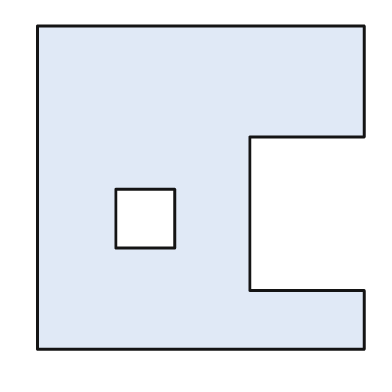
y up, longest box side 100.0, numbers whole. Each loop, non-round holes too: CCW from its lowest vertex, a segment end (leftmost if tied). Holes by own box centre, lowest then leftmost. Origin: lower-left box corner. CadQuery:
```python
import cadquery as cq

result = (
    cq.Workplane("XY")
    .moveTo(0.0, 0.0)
    .lineTo(100.0, 0.0)
    .lineTo(100.0, 18.0)
    .lineTo(65.0, 18.0)
    .lineTo(65.0, 65.0)
    .lineTo(100.0, 65.0)
    .lineTo(100.0, 99.0)
    .lineTo(0.0, 99.0)
    .close()
    .moveTo(24.0, 31.0)
    .lineTo(42.0, 31.0)
    .lineTo(42.0, 49.0)
    .lineTo(24.0, 49.0)
    .close()
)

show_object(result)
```